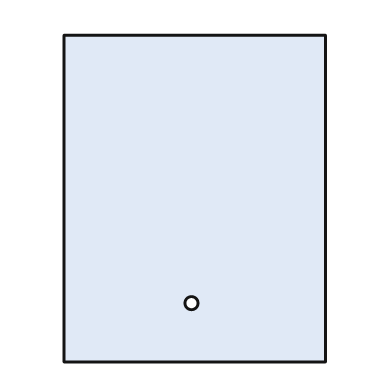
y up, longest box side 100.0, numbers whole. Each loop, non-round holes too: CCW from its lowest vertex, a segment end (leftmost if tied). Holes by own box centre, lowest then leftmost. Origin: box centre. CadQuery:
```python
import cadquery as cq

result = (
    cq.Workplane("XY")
    .moveTo(-40.0, -50.0)
    .lineTo(40.0, -50.0)
    .lineTo(40.0, 50.0)
    .lineTo(-40.0, 50.0)
    .close()
    .moveTo(-1.0, -32.0)
    .circle(2.0)
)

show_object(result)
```